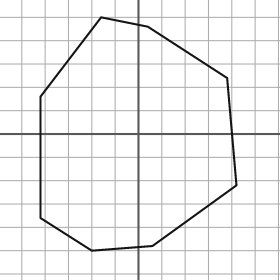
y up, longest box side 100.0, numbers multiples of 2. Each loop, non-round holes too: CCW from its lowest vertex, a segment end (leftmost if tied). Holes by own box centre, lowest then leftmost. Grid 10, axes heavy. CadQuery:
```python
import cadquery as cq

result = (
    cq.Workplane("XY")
    .moveTo(-20.0, -50.0)
    .lineTo(6.0, -48.0)
    .lineTo(42.0, -22.0)
    .lineTo(38.0, 24.0)
    .lineTo(4.0, 46.0)
    .lineTo(-16.0, 50.0)
    .lineTo(-42.0, 16.0)
    .lineTo(-42.0, -36.0)
    .close()
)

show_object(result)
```